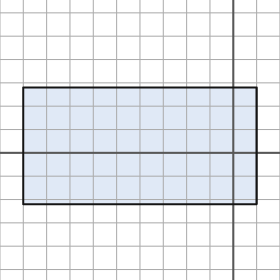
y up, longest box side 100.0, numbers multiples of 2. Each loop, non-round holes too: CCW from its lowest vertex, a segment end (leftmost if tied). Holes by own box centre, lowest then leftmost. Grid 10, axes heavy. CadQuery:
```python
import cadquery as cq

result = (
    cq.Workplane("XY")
    .moveTo(-90.0, -22.0)
    .lineTo(10.0, -22.0)
    .lineTo(10.0, 28.0)
    .lineTo(-90.0, 28.0)
    .close()
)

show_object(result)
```